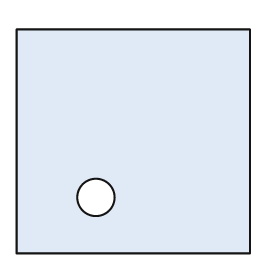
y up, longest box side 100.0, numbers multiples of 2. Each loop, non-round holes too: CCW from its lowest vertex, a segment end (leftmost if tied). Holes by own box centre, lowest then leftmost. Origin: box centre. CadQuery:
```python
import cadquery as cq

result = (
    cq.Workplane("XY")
    .moveTo(-50.0, -48.0)
    .lineTo(50.0, -48.0)
    .lineTo(50.0, 48.0)
    .lineTo(-50.0, 48.0)
    .close()
    .moveTo(-16.0, -24.0)
    .circle(8.0)
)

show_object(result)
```